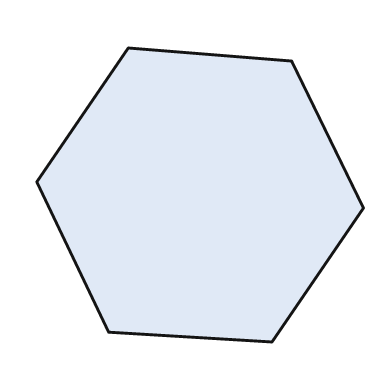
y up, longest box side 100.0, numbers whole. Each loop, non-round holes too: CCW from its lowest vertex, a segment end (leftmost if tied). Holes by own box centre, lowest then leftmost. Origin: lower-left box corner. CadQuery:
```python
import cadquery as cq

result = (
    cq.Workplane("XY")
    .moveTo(72.0, 0.0)
    .lineTo(100.0, 41.0)
    .lineTo(78.0, 86.0)
    .lineTo(28.0, 90.0)
    .lineTo(0.0, 49.0)
    .lineTo(22.0, 3.0)
    .close()
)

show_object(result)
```